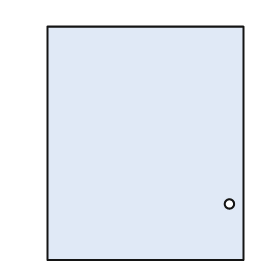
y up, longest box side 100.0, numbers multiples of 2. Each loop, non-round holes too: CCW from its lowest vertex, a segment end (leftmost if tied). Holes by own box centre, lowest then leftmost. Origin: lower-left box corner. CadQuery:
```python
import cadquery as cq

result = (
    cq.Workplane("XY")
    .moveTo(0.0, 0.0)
    .lineTo(84.0, 0.0)
    .lineTo(84.0, 100.0)
    .lineTo(0.0, 100.0)
    .close()
    .moveTo(78.0, 24.0)
    .circle(2.0)
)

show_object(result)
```